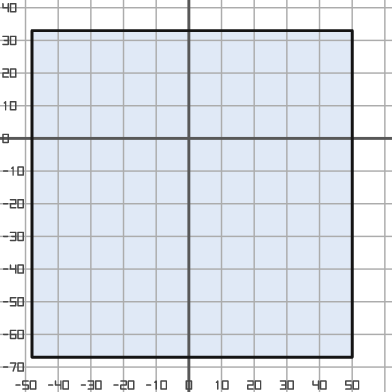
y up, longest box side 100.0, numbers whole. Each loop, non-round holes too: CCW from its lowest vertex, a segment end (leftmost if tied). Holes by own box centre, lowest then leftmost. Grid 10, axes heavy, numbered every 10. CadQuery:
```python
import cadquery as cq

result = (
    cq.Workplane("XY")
    .moveTo(-48.0, -67.0)
    .lineTo(50.0, -67.0)
    .lineTo(50.0, 33.0)
    .lineTo(-48.0, 33.0)
    .close()
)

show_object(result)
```